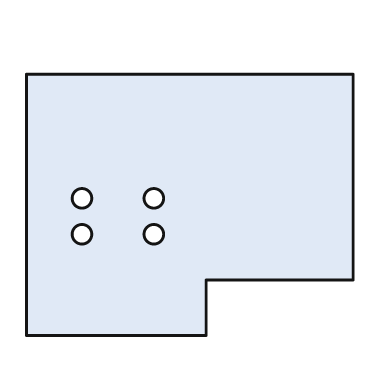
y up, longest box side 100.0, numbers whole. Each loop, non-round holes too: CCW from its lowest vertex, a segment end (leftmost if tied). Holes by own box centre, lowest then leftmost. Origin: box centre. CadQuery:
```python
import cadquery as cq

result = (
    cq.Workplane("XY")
    .moveTo(-50.0, -40.0)
    .lineTo(5.0, -40.0)
    .lineTo(5.0, -23.0)
    .lineTo(50.0, -23.0)
    .lineTo(50.0, 40.0)
    .lineTo(-50.0, 40.0)
    .close()
    .moveTo(-33.0, -9.0)
    .circle(3.0)
    .moveTo(-11.0, -9.0)
    .circle(3.0)
    .moveTo(-33.0, 2.0)
    .circle(3.0)
    .moveTo(-11.0, 2.0)
    .circle(3.0)
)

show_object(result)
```